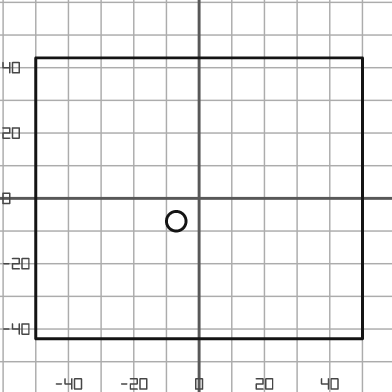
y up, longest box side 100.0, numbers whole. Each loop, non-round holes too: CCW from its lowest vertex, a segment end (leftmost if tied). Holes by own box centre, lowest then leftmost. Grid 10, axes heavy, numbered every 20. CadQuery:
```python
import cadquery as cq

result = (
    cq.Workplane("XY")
    .moveTo(-50.0, -43.0)
    .lineTo(50.0, -43.0)
    .lineTo(50.0, 43.0)
    .lineTo(-50.0, 43.0)
    .close()
    .moveTo(-7.0, -7.0)
    .circle(3.0)
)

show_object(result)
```